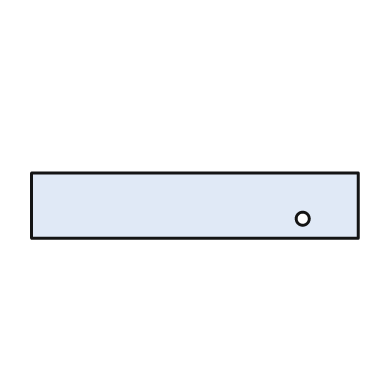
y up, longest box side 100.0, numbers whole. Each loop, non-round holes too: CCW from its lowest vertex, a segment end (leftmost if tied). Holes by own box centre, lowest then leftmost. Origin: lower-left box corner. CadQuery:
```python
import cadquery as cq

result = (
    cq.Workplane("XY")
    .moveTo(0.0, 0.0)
    .lineTo(100.0, 0.0)
    .lineTo(100.0, 20.0)
    .lineTo(0.0, 20.0)
    .close()
    .moveTo(83.0, 6.0)
    .circle(2.0)
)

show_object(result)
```